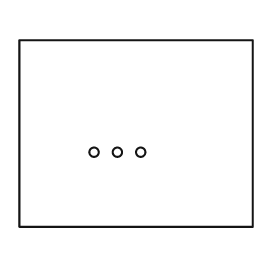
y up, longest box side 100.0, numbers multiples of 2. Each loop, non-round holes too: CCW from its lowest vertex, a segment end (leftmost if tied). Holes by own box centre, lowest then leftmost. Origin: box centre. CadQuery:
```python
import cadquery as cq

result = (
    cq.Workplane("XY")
    .moveTo(-50.0, -40.0)
    .lineTo(50.0, -40.0)
    .lineTo(50.0, 40.0)
    .lineTo(-50.0, 40.0)
    .close()
    .moveTo(-18.0, -8.0)
    .circle(2.0)
    .moveTo(-8.0, -8.0)
    .circle(2.0)
    .moveTo(2.0, -8.0)
    .circle(2.0)
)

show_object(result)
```